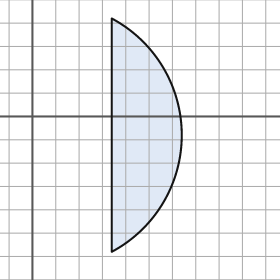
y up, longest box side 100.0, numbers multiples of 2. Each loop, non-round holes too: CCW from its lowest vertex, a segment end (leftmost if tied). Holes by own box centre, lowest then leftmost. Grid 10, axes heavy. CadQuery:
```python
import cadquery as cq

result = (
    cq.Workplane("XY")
    .moveTo(34.0, -58.0)
    .threePointArc((64.0, -8.0), (34.0, 42.0))
    .close()
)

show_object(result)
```